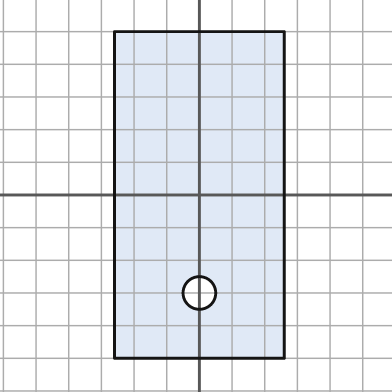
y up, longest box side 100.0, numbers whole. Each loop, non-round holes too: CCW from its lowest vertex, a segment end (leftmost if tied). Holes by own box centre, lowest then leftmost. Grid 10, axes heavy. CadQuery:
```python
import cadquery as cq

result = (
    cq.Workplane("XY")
    .moveTo(-26.0, -50.0)
    .lineTo(26.0, -50.0)
    .lineTo(26.0, 50.0)
    .lineTo(-26.0, 50.0)
    .close()
    .moveTo(0.0, -30.0)
    .circle(5.0)
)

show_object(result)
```